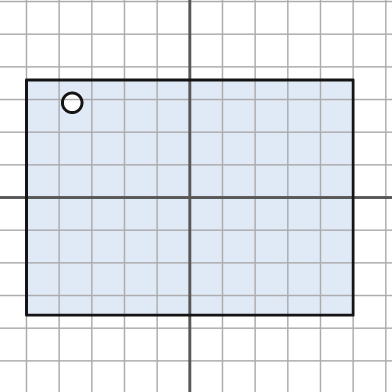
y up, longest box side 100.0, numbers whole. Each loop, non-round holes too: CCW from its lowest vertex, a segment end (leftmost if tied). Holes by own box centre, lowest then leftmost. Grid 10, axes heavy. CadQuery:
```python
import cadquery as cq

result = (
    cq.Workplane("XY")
    .moveTo(-50.0, -36.0)
    .lineTo(50.0, -36.0)
    .lineTo(50.0, 36.0)
    .lineTo(-50.0, 36.0)
    .close()
    .moveTo(-36.0, 29.0)
    .circle(3.0)
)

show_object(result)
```